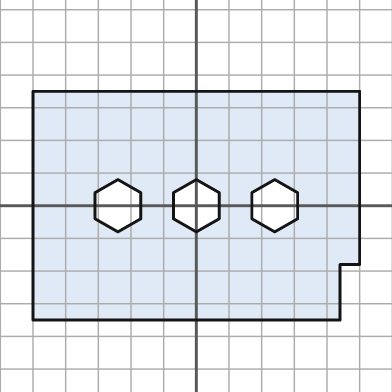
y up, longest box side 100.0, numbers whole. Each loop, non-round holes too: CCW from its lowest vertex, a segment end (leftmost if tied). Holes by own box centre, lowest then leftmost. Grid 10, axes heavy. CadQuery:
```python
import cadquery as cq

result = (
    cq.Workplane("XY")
    .moveTo(-50.0, -35.0)
    .lineTo(44.0, -35.0)
    .lineTo(44.0, -18.0)
    .lineTo(50.0, -18.0)
    .lineTo(50.0, 35.0)
    .lineTo(-50.0, 35.0)
    .close()
    .moveTo(-24.0, -8.0)
    .lineTo(-17.0, -4.0)
    .lineTo(-17.0, 4.0)
    .lineTo(-24.0, 8.0)
    .lineTo(-31.0, 4.0)
    .lineTo(-31.0, -4.0)
    .close()
    .moveTo(0.0, -8.0)
    .lineTo(7.0, -4.0)
    .lineTo(7.0, 4.0)
    .lineTo(0.0, 8.0)
    .lineTo(-7.0, 4.0)
    .lineTo(-7.0, -4.0)
    .close()
    .moveTo(24.0, -8.0)
    .lineTo(31.0, -4.0)
    .lineTo(31.0, 4.0)
    .lineTo(24.0, 8.0)
    .lineTo(17.0, 4.0)
    .lineTo(17.0, -4.0)
    .close()
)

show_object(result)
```